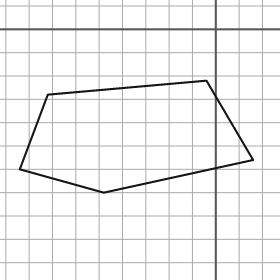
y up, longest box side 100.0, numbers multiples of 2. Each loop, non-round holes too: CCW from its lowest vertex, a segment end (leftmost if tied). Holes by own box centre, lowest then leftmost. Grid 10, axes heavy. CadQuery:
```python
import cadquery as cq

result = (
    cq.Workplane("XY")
    .moveTo(-48.0, -70.0)
    .lineTo(16.0, -56.0)
    .lineTo(-4.0, -22.0)
    .lineTo(-72.0, -28.0)
    .lineTo(-84.0, -60.0)
    .close()
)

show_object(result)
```